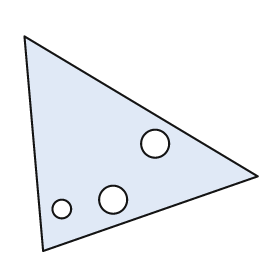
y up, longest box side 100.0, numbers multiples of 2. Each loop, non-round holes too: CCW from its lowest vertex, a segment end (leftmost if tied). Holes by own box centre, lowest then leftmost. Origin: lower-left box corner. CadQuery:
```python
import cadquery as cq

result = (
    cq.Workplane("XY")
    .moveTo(8.0, 0.0)
    .lineTo(100.0, 32.0)
    .lineTo(0.0, 92.0)
    .close()
    .moveTo(16.0, 18.0)
    .circle(4.0)
    .moveTo(38.0, 22.0)
    .circle(6.0)
    .moveTo(56.0, 46.0)
    .circle(6.0)
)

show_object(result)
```